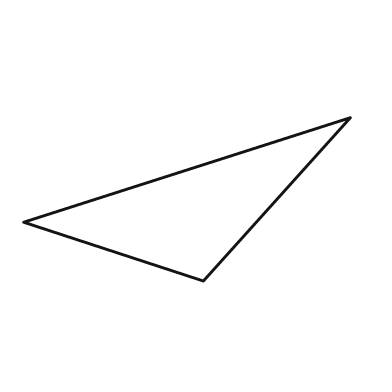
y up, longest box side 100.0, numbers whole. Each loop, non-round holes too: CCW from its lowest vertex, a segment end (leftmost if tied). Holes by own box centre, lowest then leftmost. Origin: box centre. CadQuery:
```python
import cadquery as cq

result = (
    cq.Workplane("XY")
    .moveTo(5.0, -25.0)
    .lineTo(50.0, 25.0)
    .lineTo(-50.0, -7.0)
    .close()
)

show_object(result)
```